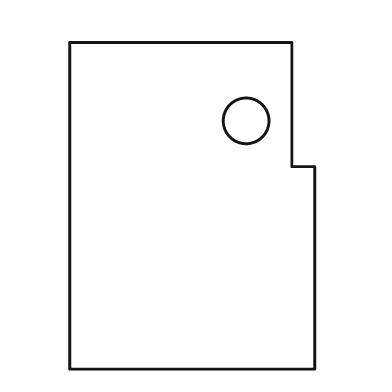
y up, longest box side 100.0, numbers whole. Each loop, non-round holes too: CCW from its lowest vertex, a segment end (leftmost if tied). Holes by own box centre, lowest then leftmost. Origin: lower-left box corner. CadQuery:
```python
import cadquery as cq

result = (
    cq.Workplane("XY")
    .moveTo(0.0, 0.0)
    .lineTo(75.0, 0.0)
    .lineTo(75.0, 62.0)
    .lineTo(68.0, 62.0)
    .lineTo(68.0, 100.0)
    .lineTo(0.0, 100.0)
    .close()
    .moveTo(54.0, 76.0)
    .circle(7.0)
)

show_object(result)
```